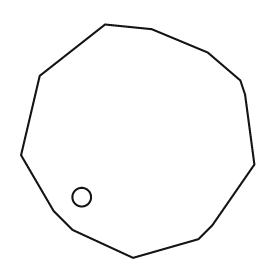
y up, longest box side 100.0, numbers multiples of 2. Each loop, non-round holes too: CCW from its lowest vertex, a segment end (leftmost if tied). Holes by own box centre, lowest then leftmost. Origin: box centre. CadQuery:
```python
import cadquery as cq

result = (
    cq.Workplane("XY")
    .moveTo(-2.0, -50.0)
    .lineTo(26.0, -42.0)
    .lineTo(32.0, -36.0)
    .lineTo(50.0, -10.0)
    .lineTo(46.0, 20.0)
    .lineTo(44.0, 26.0)
    .lineTo(30.0, 38.0)
    .lineTo(6.0, 48.0)
    .lineTo(-14.0, 50.0)
    .lineTo(-42.0, 28.0)
    .lineTo(-50.0, -6.0)
    .lineTo(-36.0, -30.0)
    .lineTo(-28.0, -38.0)
    .close()
    .moveTo(-24.0, -24.0)
    .circle(4.0)
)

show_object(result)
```